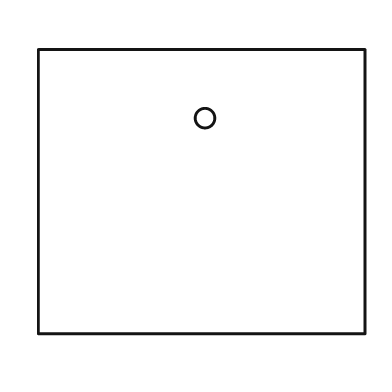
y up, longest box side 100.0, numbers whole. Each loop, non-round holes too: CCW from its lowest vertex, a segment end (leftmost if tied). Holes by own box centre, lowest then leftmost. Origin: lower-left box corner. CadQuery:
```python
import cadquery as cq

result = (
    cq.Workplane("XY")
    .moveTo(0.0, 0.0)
    .lineTo(100.0, 0.0)
    .lineTo(100.0, 87.0)
    .lineTo(0.0, 87.0)
    .close()
    .moveTo(51.0, 66.0)
    .circle(3.0)
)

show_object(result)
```